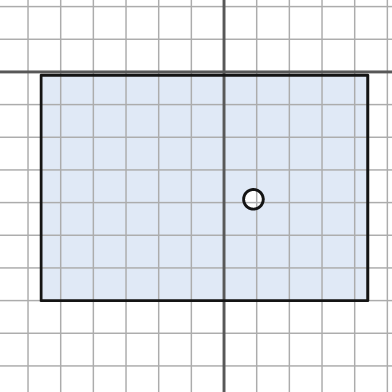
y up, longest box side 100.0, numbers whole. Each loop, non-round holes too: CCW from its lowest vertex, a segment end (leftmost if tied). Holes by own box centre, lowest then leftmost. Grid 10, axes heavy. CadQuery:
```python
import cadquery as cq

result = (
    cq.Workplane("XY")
    .moveTo(-56.0, -70.0)
    .lineTo(44.0, -70.0)
    .lineTo(44.0, -1.0)
    .lineTo(-56.0, -1.0)
    .close()
    .moveTo(9.0, -39.0)
    .circle(3.0)
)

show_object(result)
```